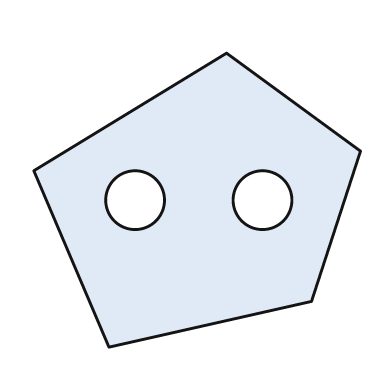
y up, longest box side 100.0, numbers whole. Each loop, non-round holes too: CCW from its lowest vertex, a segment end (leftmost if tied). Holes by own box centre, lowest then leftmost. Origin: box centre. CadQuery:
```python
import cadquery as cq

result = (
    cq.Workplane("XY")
    .moveTo(-27.0, -45.0)
    .lineTo(35.0, -31.0)
    .lineTo(50.0, 15.0)
    .lineTo(9.0, 45.0)
    .lineTo(-50.0, 9.0)
    .close()
    .moveTo(-19.0, 0.0)
    .circle(9.0)
    .moveTo(20.0, 0.0)
    .circle(9.0)
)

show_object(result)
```